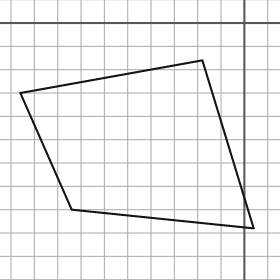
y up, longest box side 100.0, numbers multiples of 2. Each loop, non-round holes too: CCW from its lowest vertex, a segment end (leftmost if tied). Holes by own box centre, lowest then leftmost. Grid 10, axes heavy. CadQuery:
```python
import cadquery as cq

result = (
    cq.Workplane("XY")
    .moveTo(4.0, -88.0)
    .lineTo(-18.0, -16.0)
    .lineTo(-96.0, -30.0)
    .lineTo(-74.0, -80.0)
    .close()
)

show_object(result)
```